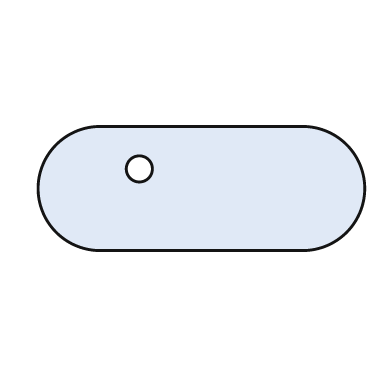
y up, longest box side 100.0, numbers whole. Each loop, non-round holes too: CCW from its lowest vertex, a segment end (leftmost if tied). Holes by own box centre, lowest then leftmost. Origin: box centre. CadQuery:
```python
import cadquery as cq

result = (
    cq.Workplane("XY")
    .moveTo(-31.0, -19.0)
    .lineTo(31.0, -19.0)
    .threePointArc((50.0, 0.0), (31.0, 19.0))
    .lineTo(-31.0, 19.0)
    .threePointArc((-50.0, 0.0), (-31.0, -19.0))
    .close()
    .moveTo(-19.0, 6.0)
    .circle(4.0)
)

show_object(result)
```